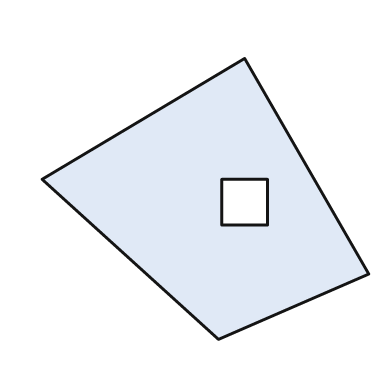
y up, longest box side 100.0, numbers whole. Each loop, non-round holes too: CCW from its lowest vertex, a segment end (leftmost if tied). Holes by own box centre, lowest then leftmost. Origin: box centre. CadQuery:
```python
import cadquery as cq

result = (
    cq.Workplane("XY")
    .moveTo(4.0, -43.0)
    .lineTo(50.0, -23.0)
    .lineTo(12.0, 43.0)
    .lineTo(-50.0, 6.0)
    .close()
    .moveTo(5.0, -8.0)
    .lineTo(19.0, -8.0)
    .lineTo(19.0, 6.0)
    .lineTo(5.0, 6.0)
    .close()
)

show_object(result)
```